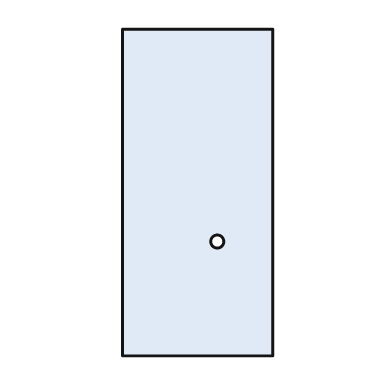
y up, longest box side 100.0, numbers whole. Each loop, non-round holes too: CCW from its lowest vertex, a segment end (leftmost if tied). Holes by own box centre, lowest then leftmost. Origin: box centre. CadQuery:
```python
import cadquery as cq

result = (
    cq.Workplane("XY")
    .moveTo(-23.0, -50.0)
    .lineTo(23.0, -50.0)
    .lineTo(23.0, 50.0)
    .lineTo(-23.0, 50.0)
    .close()
    .moveTo(6.0, -15.0)
    .circle(2.0)
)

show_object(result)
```